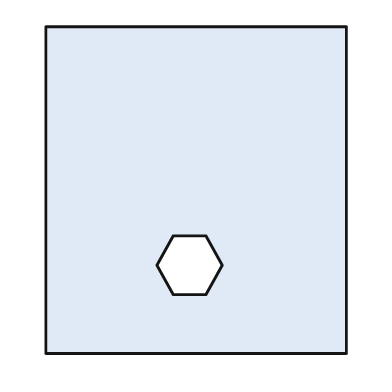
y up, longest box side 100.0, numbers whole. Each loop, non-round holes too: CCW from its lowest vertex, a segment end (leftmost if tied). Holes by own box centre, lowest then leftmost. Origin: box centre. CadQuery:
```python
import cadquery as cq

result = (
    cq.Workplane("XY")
    .moveTo(-46.0, -50.0)
    .lineTo(46.0, -50.0)
    .lineTo(46.0, 50.0)
    .lineTo(-46.0, 50.0)
    .close()
    .moveTo(-7.0, -32.0)
    .lineTo(3.0, -32.0)
    .lineTo(8.0, -23.0)
    .lineTo(3.0, -14.0)
    .lineTo(-7.0, -14.0)
    .lineTo(-12.0, -23.0)
    .close()
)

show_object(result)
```